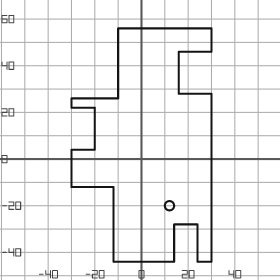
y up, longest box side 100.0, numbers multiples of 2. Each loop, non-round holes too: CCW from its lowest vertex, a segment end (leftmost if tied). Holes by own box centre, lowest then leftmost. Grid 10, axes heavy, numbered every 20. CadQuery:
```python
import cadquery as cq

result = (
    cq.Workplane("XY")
    .moveTo(-12.0, -44.0)
    .lineTo(14.0, -44.0)
    .lineTo(14.0, -28.0)
    .lineTo(24.0, -28.0)
    .lineTo(24.0, -44.0)
    .lineTo(30.0, -44.0)
    .lineTo(30.0, 28.0)
    .lineTo(16.0, 28.0)
    .lineTo(16.0, 46.0)
    .lineTo(30.0, 46.0)
    .lineTo(30.0, 56.0)
    .lineTo(-10.0, 56.0)
    .lineTo(-10.0, 26.0)
    .lineTo(-30.0, 26.0)
    .lineTo(-30.0, 22.0)
    .lineTo(-20.0, 22.0)
    .lineTo(-20.0, 4.0)
    .lineTo(-30.0, 4.0)
    .lineTo(-30.0, -12.0)
    .lineTo(-12.0, -12.0)
    .close()
    .moveTo(12.0, -20.0)
    .circle(2.0)
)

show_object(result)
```